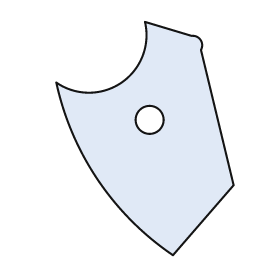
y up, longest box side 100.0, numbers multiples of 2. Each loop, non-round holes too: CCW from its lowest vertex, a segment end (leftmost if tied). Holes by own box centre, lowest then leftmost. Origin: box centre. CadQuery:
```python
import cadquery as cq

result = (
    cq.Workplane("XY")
    .moveTo(12.0, -50.0)
    .lineTo(38.0, -20.0)
    .lineTo(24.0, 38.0)
    .threePointArc((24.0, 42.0), (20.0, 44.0))
    .lineTo(0.0, 50.0)
    .threePointArc((-10.0, 24.0), (-38.0, 24.0))
    .threePointArc((-20.0, -18.0), (12.0, -50.0))
    .close()
    .moveTo(2.0, 8.0)
    .circle(6.0)
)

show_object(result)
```